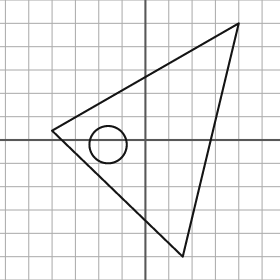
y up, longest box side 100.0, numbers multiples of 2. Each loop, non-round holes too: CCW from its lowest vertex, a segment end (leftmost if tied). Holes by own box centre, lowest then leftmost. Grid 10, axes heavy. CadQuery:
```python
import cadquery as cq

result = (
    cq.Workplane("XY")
    .moveTo(16.0, -50.0)
    .lineTo(40.0, 50.0)
    .lineTo(-40.0, 4.0)
    .close()
    .moveTo(-16.0, -2.0)
    .circle(8.0)
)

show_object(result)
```